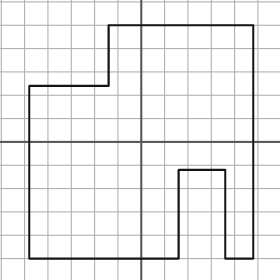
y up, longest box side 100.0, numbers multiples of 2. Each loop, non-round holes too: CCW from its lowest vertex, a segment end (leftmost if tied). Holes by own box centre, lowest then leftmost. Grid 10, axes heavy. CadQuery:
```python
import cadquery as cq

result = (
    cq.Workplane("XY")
    .moveTo(-48.0, -50.0)
    .lineTo(16.0, -50.0)
    .lineTo(16.0, -12.0)
    .lineTo(36.0, -12.0)
    .lineTo(36.0, -50.0)
    .lineTo(48.0, -50.0)
    .lineTo(48.0, 50.0)
    .lineTo(-14.0, 50.0)
    .lineTo(-14.0, 24.0)
    .lineTo(-48.0, 24.0)
    .close()
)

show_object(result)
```